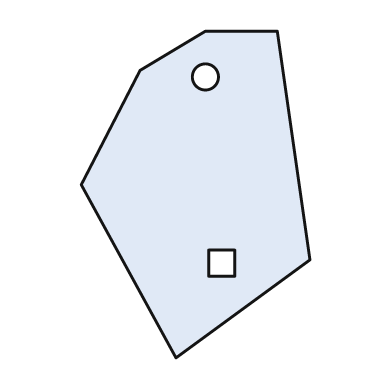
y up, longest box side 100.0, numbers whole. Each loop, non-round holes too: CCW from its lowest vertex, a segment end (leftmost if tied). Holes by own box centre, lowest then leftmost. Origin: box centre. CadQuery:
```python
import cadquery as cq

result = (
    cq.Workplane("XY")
    .moveTo(-6.0, -50.0)
    .lineTo(35.0, -20.0)
    .lineTo(25.0, 50.0)
    .lineTo(3.0, 50.0)
    .lineTo(-17.0, 38.0)
    .lineTo(-35.0, 3.0)
    .close()
    .moveTo(4.0, -25.0)
    .lineTo(12.0, -25.0)
    .lineTo(12.0, -17.0)
    .lineTo(4.0, -17.0)
    .close()
    .moveTo(3.0, 36.0)
    .circle(4.0)
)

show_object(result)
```